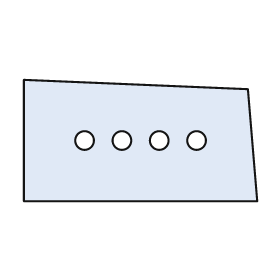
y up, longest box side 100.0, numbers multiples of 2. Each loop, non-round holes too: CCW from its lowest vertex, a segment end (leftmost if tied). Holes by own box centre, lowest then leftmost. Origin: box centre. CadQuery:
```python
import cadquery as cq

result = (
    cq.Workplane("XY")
    .moveTo(-50.0, -26.0)
    .lineTo(50.0, -26.0)
    .lineTo(46.0, 22.0)
    .lineTo(-50.0, 26.0)
    .close()
    .moveTo(-24.0, 0.0)
    .circle(4.0)
    .moveTo(-8.0, 0.0)
    .circle(4.0)
    .moveTo(8.0, 0.0)
    .circle(4.0)
    .moveTo(24.0, 0.0)
    .circle(4.0)
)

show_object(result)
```